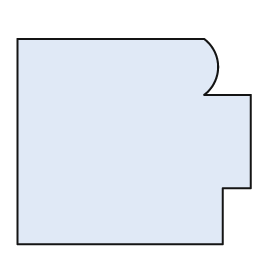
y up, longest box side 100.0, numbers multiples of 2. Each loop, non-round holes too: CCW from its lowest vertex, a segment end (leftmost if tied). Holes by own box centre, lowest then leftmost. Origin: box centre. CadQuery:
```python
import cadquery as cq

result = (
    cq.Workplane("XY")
    .moveTo(-50.0, -44.0)
    .lineTo(38.0, -44.0)
    .lineTo(38.0, -20.0)
    .lineTo(50.0, -20.0)
    .lineTo(50.0, 20.0)
    .lineTo(30.0, 20.0)
    .threePointArc((36.0, 32.0), (30.0, 44.0))
    .lineTo(-50.0, 44.0)
    .close()
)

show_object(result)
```